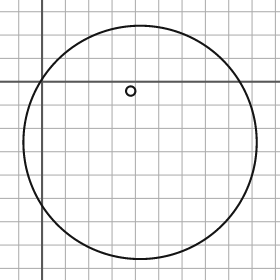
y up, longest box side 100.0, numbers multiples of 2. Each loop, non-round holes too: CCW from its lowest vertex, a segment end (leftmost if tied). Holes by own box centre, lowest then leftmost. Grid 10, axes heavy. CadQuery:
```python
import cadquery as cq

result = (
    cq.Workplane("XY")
    .moveTo(42.0, -26.0)
    .circle(50.0)
    .moveTo(38.0, -4.0)
    .circle(2.0)
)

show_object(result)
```